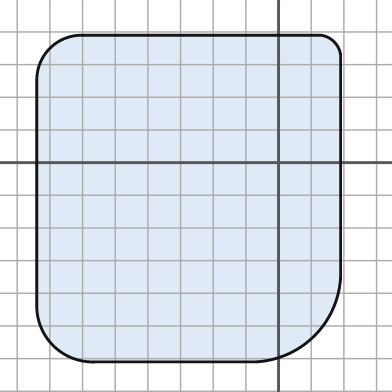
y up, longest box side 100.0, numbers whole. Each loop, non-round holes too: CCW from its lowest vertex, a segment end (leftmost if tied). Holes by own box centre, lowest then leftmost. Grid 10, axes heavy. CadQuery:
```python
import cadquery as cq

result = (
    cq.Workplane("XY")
    .moveTo(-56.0, -61.0)
    .lineTo(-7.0, -61.0)
    .threePointArc((11.0, -53.0), (19.0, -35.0))
    .lineTo(19.0, 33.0)
    .threePointArc((17.0, 37.0), (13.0, 39.0))
    .lineTo(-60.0, 39.0)
    .threePointArc((-70.0, 35.0), (-74.0, 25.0))
    .lineTo(-74.0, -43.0)
    .threePointArc((-69.0, -56.0), (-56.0, -61.0))
    .close()
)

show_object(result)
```